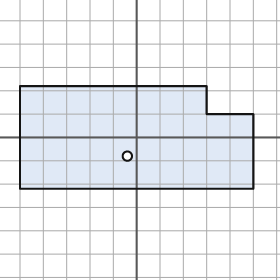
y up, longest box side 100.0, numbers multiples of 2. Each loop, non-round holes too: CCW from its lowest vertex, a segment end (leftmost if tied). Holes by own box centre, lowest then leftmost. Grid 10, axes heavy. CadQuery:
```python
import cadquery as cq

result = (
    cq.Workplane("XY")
    .moveTo(-50.0, -22.0)
    .lineTo(50.0, -22.0)
    .lineTo(50.0, 10.0)
    .lineTo(30.0, 10.0)
    .lineTo(30.0, 22.0)
    .lineTo(-50.0, 22.0)
    .close()
    .moveTo(-4.0, -8.0)
    .circle(2.0)
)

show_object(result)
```